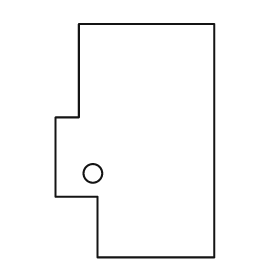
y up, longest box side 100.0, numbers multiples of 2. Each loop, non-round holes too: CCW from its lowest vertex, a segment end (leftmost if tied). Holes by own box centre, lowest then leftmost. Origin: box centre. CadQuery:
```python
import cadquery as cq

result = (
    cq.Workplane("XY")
    .moveTo(-16.0, -50.0)
    .lineTo(34.0, -50.0)
    .lineTo(34.0, 50.0)
    .lineTo(-24.0, 50.0)
    .lineTo(-24.0, 10.0)
    .lineTo(-34.0, 10.0)
    .lineTo(-34.0, -24.0)
    .lineTo(-16.0, -24.0)
    .close()
    .moveTo(-18.0, -14.0)
    .circle(4.0)
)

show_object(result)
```